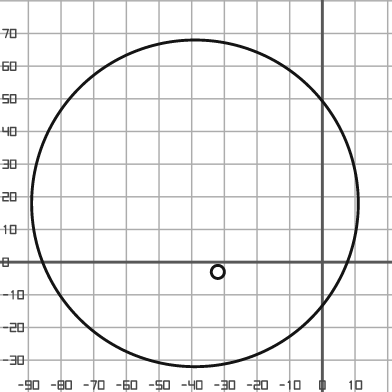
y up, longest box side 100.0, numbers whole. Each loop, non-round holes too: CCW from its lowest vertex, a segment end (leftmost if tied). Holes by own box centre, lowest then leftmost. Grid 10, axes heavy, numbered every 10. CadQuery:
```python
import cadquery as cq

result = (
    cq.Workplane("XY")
    .moveTo(-39.0, 18.0)
    .circle(50.0)
    .moveTo(-32.0, -3.0)
    .circle(2.0)
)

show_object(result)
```